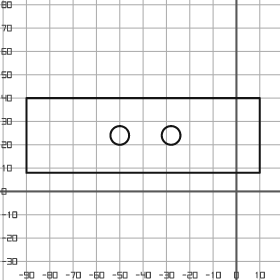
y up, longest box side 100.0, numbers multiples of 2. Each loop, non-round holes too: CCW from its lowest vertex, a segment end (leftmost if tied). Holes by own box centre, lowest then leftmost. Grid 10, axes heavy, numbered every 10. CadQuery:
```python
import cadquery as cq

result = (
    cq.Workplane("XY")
    .moveTo(-90.0, 8.0)
    .lineTo(10.0, 8.0)
    .lineTo(10.0, 40.0)
    .lineTo(-90.0, 40.0)
    .close()
    .moveTo(-50.0, 24.0)
    .circle(4.0)
    .moveTo(-28.0, 24.0)
    .circle(4.0)
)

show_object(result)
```